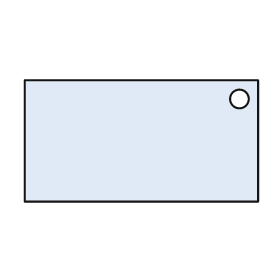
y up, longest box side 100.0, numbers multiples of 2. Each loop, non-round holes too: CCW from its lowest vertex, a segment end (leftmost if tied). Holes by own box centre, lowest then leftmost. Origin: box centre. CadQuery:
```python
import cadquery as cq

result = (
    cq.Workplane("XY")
    .moveTo(-50.0, -26.0)
    .lineTo(50.0, -26.0)
    .lineTo(50.0, 26.0)
    .lineTo(-50.0, 26.0)
    .close()
    .moveTo(42.0, 18.0)
    .circle(4.0)
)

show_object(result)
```